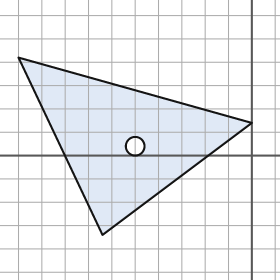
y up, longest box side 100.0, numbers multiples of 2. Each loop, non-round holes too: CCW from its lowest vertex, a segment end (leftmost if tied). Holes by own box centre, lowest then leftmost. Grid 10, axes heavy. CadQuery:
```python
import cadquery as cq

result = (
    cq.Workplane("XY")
    .moveTo(-64.0, -34.0)
    .lineTo(0.0, 14.0)
    .lineTo(-100.0, 42.0)
    .close()
    .moveTo(-50.0, 4.0)
    .circle(4.0)
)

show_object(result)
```